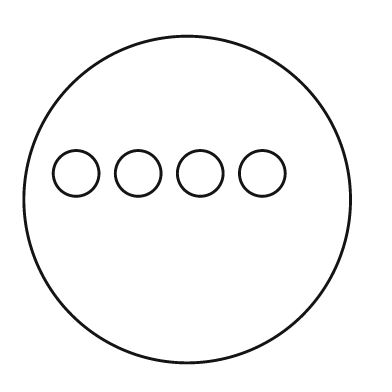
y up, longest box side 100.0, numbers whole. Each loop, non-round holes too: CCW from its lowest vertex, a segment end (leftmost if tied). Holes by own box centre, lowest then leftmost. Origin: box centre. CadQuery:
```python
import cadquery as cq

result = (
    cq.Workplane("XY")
    .moveTo(0.0, 0.0)
    .circle(50.0)
    .moveTo(-34.0, 8.0)
    .circle(7.0)
    .moveTo(-15.0, 8.0)
    .circle(7.0)
    .moveTo(4.0, 8.0)
    .circle(7.0)
    .moveTo(23.0, 8.0)
    .circle(7.0)
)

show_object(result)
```